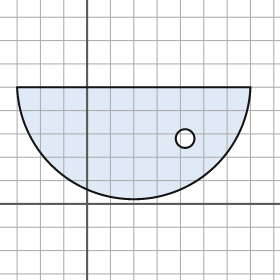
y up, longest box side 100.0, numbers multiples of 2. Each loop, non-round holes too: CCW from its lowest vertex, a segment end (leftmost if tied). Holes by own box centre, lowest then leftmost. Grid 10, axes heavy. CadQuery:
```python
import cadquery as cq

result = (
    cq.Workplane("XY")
    .moveTo(-30.0, 50.0)
    .threePointArc((20.0, 2.0), (70.0, 50.0))
    .close()
    .moveTo(42.0, 28.0)
    .circle(4.0)
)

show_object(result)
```